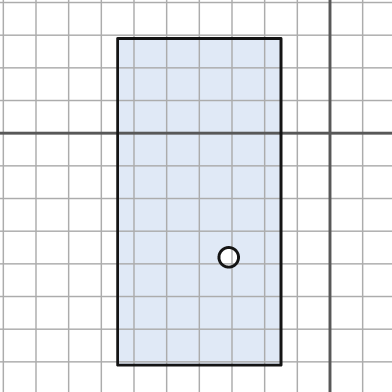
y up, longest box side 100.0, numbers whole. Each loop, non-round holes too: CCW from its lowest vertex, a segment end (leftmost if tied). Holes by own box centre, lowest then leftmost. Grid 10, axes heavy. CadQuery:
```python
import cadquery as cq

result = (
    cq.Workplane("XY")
    .moveTo(-65.0, -71.0)
    .lineTo(-15.0, -71.0)
    .lineTo(-15.0, 29.0)
    .lineTo(-65.0, 29.0)
    .close()
    .moveTo(-31.0, -38.0)
    .circle(3.0)
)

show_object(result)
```